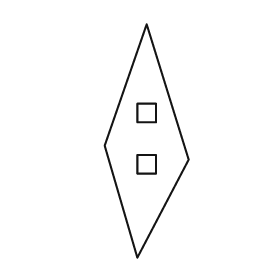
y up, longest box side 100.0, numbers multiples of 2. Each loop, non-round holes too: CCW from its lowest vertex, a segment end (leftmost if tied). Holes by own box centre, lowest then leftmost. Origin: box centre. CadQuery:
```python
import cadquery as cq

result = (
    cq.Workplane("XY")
    .moveTo(-4.0, -50.0)
    .lineTo(18.0, -8.0)
    .lineTo(0.0, 50.0)
    .lineTo(-18.0, -2.0)
    .close()
    .moveTo(-4.0, -14.0)
    .lineTo(4.0, -14.0)
    .lineTo(4.0, -6.0)
    .lineTo(-4.0, -6.0)
    .close()
    .moveTo(-4.0, 8.0)
    .lineTo(4.0, 8.0)
    .lineTo(4.0, 16.0)
    .lineTo(-4.0, 16.0)
    .close()
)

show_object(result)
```